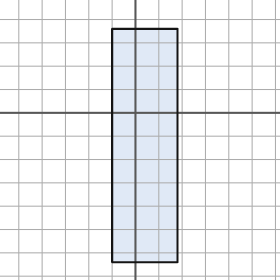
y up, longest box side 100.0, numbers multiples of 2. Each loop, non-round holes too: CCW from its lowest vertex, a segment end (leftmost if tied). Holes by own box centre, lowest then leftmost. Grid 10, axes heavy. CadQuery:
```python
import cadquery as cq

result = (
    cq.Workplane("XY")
    .moveTo(-10.0, -64.0)
    .lineTo(18.0, -64.0)
    .lineTo(18.0, 36.0)
    .lineTo(-10.0, 36.0)
    .close()
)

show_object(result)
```